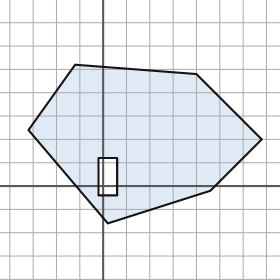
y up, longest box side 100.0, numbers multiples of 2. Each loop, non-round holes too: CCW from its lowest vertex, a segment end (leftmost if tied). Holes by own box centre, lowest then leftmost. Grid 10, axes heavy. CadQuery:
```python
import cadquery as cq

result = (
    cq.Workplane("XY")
    .moveTo(2.0, -16.0)
    .lineTo(46.0, -2.0)
    .lineTo(68.0, 20.0)
    .lineTo(40.0, 48.0)
    .lineTo(-12.0, 52.0)
    .lineTo(-32.0, 24.0)
    .close()
    .moveTo(-2.0, -4.0)
    .lineTo(6.0, -4.0)
    .lineTo(6.0, 12.0)
    .lineTo(-2.0, 12.0)
    .close()
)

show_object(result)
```